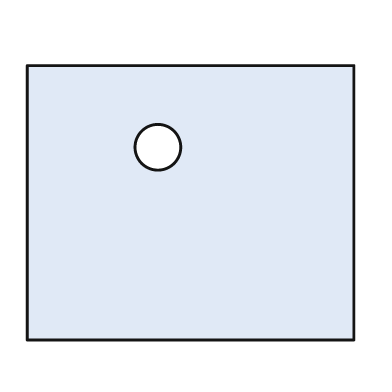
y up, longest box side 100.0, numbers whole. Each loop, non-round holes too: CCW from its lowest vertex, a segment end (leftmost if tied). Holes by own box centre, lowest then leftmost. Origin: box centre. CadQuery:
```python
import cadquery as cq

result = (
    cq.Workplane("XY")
    .moveTo(-50.0, -42.0)
    .lineTo(50.0, -42.0)
    .lineTo(50.0, 42.0)
    .lineTo(-50.0, 42.0)
    .close()
    .moveTo(-10.0, 17.0)
    .circle(7.0)
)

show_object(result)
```